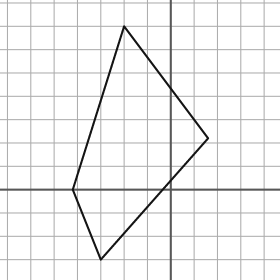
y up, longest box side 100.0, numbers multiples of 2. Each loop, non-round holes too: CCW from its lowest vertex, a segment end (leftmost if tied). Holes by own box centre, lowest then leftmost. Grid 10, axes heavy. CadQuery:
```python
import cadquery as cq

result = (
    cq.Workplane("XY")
    .moveTo(-30.0, -30.0)
    .lineTo(16.0, 22.0)
    .lineTo(-20.0, 70.0)
    .lineTo(-42.0, 0.0)
    .close()
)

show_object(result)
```